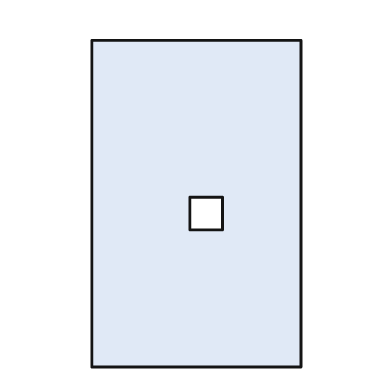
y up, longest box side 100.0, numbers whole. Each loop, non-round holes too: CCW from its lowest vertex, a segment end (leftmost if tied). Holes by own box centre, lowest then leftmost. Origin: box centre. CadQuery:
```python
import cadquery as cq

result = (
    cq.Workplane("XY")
    .moveTo(-32.0, -50.0)
    .lineTo(32.0, -50.0)
    .lineTo(32.0, 50.0)
    .lineTo(-32.0, 50.0)
    .close()
    .moveTo(-2.0, -8.0)
    .lineTo(8.0, -8.0)
    .lineTo(8.0, 2.0)
    .lineTo(-2.0, 2.0)
    .close()
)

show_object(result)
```